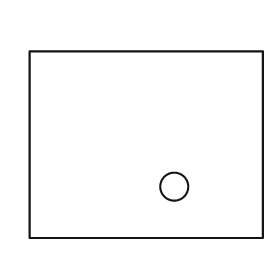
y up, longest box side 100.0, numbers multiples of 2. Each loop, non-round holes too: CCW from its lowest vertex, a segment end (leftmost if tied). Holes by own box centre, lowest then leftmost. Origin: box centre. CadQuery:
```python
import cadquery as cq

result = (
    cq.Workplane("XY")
    .moveTo(-50.0, -40.0)
    .lineTo(50.0, -40.0)
    .lineTo(50.0, 40.0)
    .lineTo(-50.0, 40.0)
    .close()
    .moveTo(12.0, -18.0)
    .circle(6.0)
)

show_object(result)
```